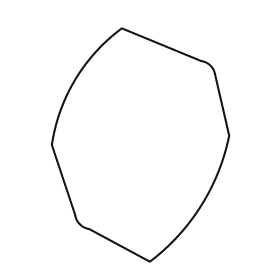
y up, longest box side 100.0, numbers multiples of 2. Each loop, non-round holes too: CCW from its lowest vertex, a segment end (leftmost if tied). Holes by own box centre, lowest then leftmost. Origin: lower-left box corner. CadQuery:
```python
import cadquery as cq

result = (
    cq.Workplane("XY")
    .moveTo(42.0, 0.0)
    .threePointArc((64.0, 24.0), (76.0, 54.0))
    .lineTo(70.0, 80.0)
    .threePointArc((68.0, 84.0), (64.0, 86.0))
    .lineTo(30.0, 100.0)
    .threePointArc((10.0, 78.0), (0.0, 50.0))
    .lineTo(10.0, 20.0)
    .threePointArc((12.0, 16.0), (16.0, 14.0))
    .close()
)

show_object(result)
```